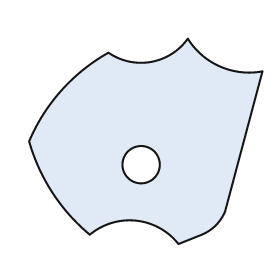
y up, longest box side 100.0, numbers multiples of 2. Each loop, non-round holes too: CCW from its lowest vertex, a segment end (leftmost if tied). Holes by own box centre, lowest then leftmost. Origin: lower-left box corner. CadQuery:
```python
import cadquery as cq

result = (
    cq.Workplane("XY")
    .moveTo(64.0, 0.0)
    .lineTo(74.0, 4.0)
    .threePointArc((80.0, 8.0), (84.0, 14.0))
    .lineTo(100.0, 74.0)
    .threePointArc((82.0, 76.0), (68.0, 88.0))
    .threePointArc((52.0, 78.0), (34.0, 82.0))
    .threePointArc((14.0, 66.0), (0.0, 44.0))
    .threePointArc((10.0, 22.0), (26.0, 4.0))
    .threePointArc((46.0, 10.0), (64.0, 0.0))
    .close()
    .moveTo(48.0, 34.0)
    .circle(8.0)
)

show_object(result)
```